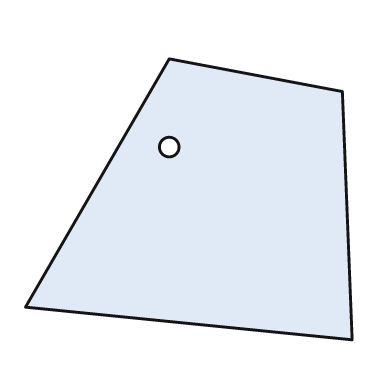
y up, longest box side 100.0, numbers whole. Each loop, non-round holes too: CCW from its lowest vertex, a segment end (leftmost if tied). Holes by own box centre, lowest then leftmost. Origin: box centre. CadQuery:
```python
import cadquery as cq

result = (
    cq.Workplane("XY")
    .moveTo(50.0, -43.0)
    .lineTo(47.0, 33.0)
    .lineTo(-6.0, 43.0)
    .lineTo(-50.0, -33.0)
    .close()
    .moveTo(-6.0, 16.0)
    .circle(3.0)
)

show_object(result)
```